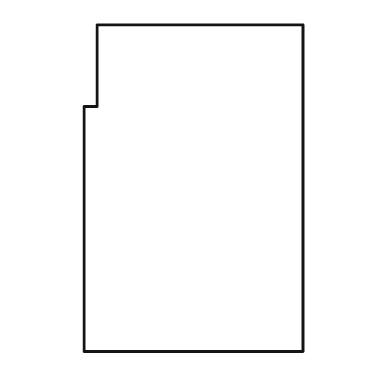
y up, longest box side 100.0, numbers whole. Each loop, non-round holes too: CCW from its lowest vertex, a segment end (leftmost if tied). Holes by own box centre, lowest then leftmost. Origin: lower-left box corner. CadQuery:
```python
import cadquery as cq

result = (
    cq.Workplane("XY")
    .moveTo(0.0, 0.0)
    .lineTo(67.0, 0.0)
    .lineTo(67.0, 100.0)
    .lineTo(4.0, 100.0)
    .lineTo(4.0, 75.0)
    .lineTo(0.0, 75.0)
    .close()
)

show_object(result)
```